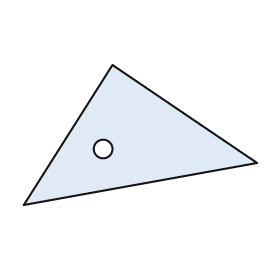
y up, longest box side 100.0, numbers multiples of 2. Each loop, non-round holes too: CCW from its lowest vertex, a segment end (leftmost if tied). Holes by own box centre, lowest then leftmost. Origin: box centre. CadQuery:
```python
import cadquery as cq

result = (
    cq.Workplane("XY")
    .moveTo(-50.0, -30.0)
    .lineTo(50.0, -12.0)
    .lineTo(-12.0, 30.0)
    .close()
    .moveTo(-16.0, -6.0)
    .circle(4.0)
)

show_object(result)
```